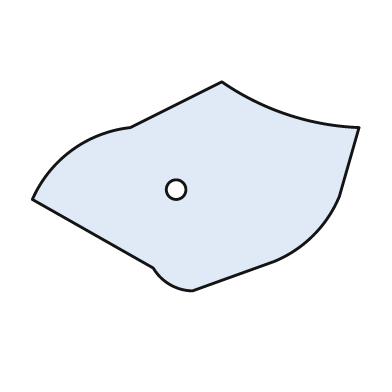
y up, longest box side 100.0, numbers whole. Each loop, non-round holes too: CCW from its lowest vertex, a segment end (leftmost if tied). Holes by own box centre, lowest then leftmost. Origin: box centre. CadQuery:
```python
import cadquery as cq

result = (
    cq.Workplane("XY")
    .moveTo(-1.0, -32.0)
    .lineTo(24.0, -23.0)
    .threePointArc((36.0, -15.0), (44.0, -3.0))
    .lineTo(50.0, 18.0)
    .threePointArc((28.0, 22.0), (8.0, 32.0))
    .lineTo(-20.0, 18.0)
    .threePointArc((-38.0, 11.0), (-50.0, -4.0))
    .lineTo(-13.0, -25.0)
    .threePointArc((-8.0, -30.0), (-1.0, -32.0))
    .close()
    .moveTo(-6.0, -1.0)
    .circle(3.0)
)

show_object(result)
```